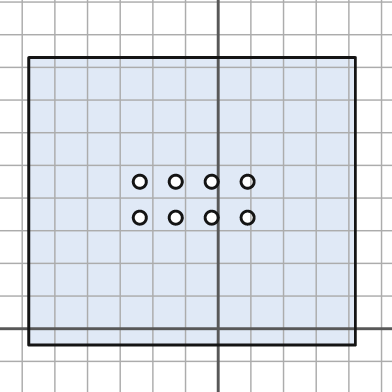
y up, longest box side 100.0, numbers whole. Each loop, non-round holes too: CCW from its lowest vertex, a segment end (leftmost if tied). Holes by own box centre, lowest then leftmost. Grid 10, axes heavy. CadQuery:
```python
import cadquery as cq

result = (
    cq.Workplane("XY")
    .moveTo(-58.0, -5.0)
    .lineTo(42.0, -5.0)
    .lineTo(42.0, 83.0)
    .lineTo(-58.0, 83.0)
    .close()
    .moveTo(-24.0, 34.0)
    .circle(2.0)
    .moveTo(-13.0, 34.0)
    .circle(2.0)
    .moveTo(-2.0, 34.0)
    .circle(2.0)
    .moveTo(9.0, 34.0)
    .circle(2.0)
    .moveTo(-24.0, 45.0)
    .circle(2.0)
    .moveTo(-13.0, 45.0)
    .circle(2.0)
    .moveTo(-2.0, 45.0)
    .circle(2.0)
    .moveTo(9.0, 45.0)
    .circle(2.0)
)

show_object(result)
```